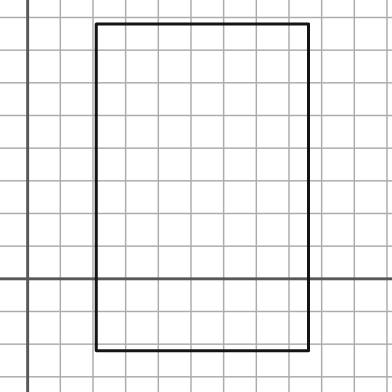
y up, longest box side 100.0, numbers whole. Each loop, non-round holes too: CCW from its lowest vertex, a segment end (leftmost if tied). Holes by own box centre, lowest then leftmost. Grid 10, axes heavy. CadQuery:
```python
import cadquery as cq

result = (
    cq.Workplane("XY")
    .moveTo(21.0, -22.0)
    .lineTo(86.0, -22.0)
    .lineTo(86.0, 78.0)
    .lineTo(21.0, 78.0)
    .close()
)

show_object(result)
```